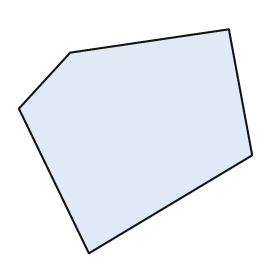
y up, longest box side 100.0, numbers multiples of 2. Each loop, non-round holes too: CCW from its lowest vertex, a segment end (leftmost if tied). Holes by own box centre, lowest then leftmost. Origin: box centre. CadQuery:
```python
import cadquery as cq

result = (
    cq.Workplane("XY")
    .moveTo(-20.0, -48.0)
    .lineTo(50.0, -6.0)
    .lineTo(40.0, 48.0)
    .lineTo(-28.0, 38.0)
    .lineTo(-50.0, 14.0)
    .close()
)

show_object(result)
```